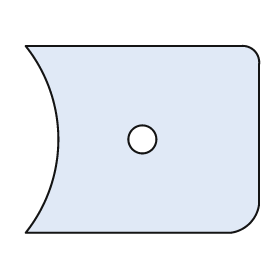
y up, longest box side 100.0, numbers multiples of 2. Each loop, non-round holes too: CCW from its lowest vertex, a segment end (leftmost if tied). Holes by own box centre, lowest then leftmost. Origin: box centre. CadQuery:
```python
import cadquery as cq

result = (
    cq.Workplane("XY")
    .moveTo(-50.0, -40.0)
    .lineTo(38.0, -40.0)
    .threePointArc((46.0, -36.0), (50.0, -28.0))
    .lineTo(50.0, 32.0)
    .threePointArc((48.0, 38.0), (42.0, 40.0))
    .lineTo(-50.0, 40.0)
    .threePointArc((-36.0, 0.0), (-50.0, -40.0))
    .close()
    .moveTo(0.0, 0.0)
    .circle(6.0)
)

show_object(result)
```